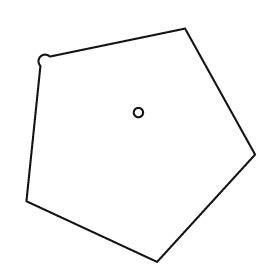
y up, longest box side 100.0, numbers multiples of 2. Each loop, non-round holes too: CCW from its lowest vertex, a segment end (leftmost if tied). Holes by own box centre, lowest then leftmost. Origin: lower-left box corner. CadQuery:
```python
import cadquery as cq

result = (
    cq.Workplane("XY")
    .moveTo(56.0, 0.0)
    .lineTo(98.0, 46.0)
    .lineTo(68.0, 100.0)
    .lineTo(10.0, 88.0)
    .threePointArc((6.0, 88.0), (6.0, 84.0))
    .lineTo(0.0, 26.0)
    .close()
    .moveTo(48.0, 64.0)
    .circle(2.0)
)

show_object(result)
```